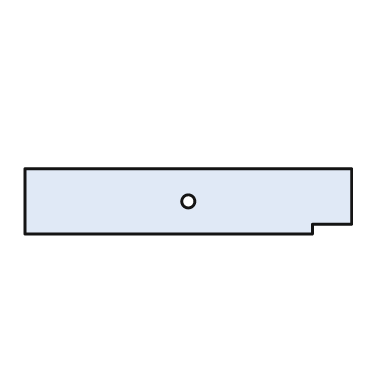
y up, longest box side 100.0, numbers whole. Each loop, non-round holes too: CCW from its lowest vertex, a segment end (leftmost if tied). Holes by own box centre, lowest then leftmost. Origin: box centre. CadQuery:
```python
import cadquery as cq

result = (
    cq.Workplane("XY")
    .moveTo(-50.0, -10.0)
    .lineTo(38.0, -10.0)
    .lineTo(38.0, -7.0)
    .lineTo(50.0, -7.0)
    .lineTo(50.0, 10.0)
    .lineTo(-50.0, 10.0)
    .close()
    .moveTo(0.0, 0.0)
    .circle(2.0)
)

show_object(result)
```